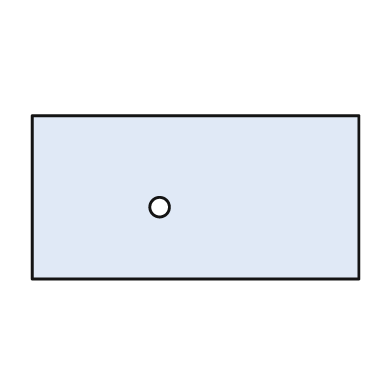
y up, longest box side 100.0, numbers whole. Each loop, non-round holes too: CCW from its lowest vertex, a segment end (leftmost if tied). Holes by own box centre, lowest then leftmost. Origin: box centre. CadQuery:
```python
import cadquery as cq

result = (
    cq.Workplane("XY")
    .moveTo(-50.0, -25.0)
    .lineTo(50.0, -25.0)
    .lineTo(50.0, 25.0)
    .lineTo(-50.0, 25.0)
    .close()
    .moveTo(-11.0, -3.0)
    .circle(3.0)
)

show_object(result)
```